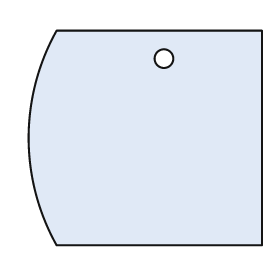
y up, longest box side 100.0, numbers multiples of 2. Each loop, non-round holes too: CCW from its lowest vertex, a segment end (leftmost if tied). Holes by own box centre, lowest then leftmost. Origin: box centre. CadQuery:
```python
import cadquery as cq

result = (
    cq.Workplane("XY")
    .moveTo(-38.0, -46.0)
    .lineTo(50.0, -46.0)
    .lineTo(50.0, 46.0)
    .lineTo(-38.0, 46.0)
    .threePointArc((-50.0, 0.0), (-38.0, -46.0))
    .close()
    .moveTo(8.0, 34.0)
    .circle(4.0)
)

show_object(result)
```